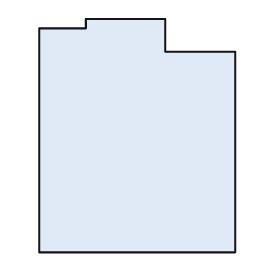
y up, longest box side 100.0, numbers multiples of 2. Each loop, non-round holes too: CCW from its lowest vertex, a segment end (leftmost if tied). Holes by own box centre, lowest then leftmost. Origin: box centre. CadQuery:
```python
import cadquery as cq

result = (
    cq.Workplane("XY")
    .moveTo(-42.0, -50.0)
    .lineTo(42.0, -50.0)
    .lineTo(42.0, 36.0)
    .lineTo(12.0, 36.0)
    .lineTo(12.0, 50.0)
    .lineTo(-22.0, 50.0)
    .lineTo(-22.0, 46.0)
    .lineTo(-42.0, 46.0)
    .close()
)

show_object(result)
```